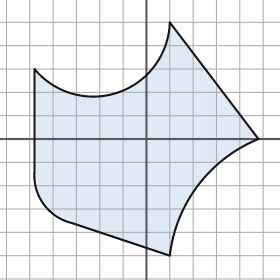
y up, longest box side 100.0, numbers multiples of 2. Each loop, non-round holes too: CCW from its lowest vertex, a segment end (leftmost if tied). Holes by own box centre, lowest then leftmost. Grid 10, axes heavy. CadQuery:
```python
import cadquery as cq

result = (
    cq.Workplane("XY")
    .moveTo(10.0, -50.0)
    .threePointArc((22.0, -20.0), (48.0, 0.0))
    .lineTo(10.0, 50.0)
    .threePointArc((-12.0, 20.0), (-48.0, 30.0))
    .lineTo(-48.0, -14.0)
    .threePointArc((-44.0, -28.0), (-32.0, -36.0))
    .close()
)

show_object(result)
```